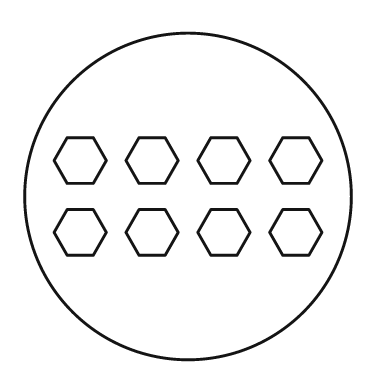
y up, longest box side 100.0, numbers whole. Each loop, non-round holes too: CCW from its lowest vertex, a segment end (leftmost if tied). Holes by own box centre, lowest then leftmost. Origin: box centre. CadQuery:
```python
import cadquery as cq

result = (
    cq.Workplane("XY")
    .moveTo(0.0, 0.0)
    .circle(50.0)
    .moveTo(-37.0, -18.0)
    .lineTo(-29.0, -18.0)
    .lineTo(-25.0, -11.0)
    .lineTo(-29.0, -4.0)
    .lineTo(-37.0, -4.0)
    .lineTo(-41.0, -11.0)
    .close()
    .moveTo(-15.0, -18.0)
    .lineTo(-7.0, -18.0)
    .lineTo(-3.0, -11.0)
    .lineTo(-7.0, -4.0)
    .lineTo(-15.0, -4.0)
    .lineTo(-19.0, -11.0)
    .close()
    .moveTo(7.0, -18.0)
    .lineTo(15.0, -18.0)
    .lineTo(19.0, -11.0)
    .lineTo(15.0, -4.0)
    .lineTo(7.0, -4.0)
    .lineTo(3.0, -11.0)
    .close()
    .moveTo(29.0, -18.0)
    .lineTo(37.0, -18.0)
    .lineTo(41.0, -11.0)
    .lineTo(37.0, -4.0)
    .lineTo(29.0, -4.0)
    .lineTo(25.0, -11.0)
    .close()
    .moveTo(-37.0, 4.0)
    .lineTo(-29.0, 4.0)
    .lineTo(-25.0, 11.0)
    .lineTo(-29.0, 18.0)
    .lineTo(-37.0, 18.0)
    .lineTo(-41.0, 11.0)
    .close()
    .moveTo(-15.0, 4.0)
    .lineTo(-7.0, 4.0)
    .lineTo(-3.0, 11.0)
    .lineTo(-7.0, 18.0)
    .lineTo(-15.0, 18.0)
    .lineTo(-19.0, 11.0)
    .close()
    .moveTo(7.0, 4.0)
    .lineTo(15.0, 4.0)
    .lineTo(19.0, 11.0)
    .lineTo(15.0, 18.0)
    .lineTo(7.0, 18.0)
    .lineTo(3.0, 11.0)
    .close()
    .moveTo(29.0, 4.0)
    .lineTo(37.0, 4.0)
    .lineTo(41.0, 11.0)
    .lineTo(37.0, 18.0)
    .lineTo(29.0, 18.0)
    .lineTo(25.0, 11.0)
    .close()
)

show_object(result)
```